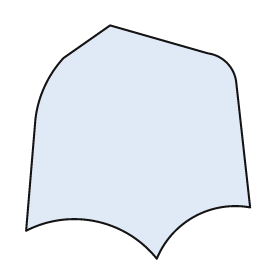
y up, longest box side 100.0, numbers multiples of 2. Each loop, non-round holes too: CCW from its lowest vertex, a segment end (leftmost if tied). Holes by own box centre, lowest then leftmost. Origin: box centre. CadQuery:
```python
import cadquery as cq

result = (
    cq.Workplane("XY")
    .moveTo(8.0, -50.0)
    .threePointArc((24.0, -32.0), (48.0, -28.0))
    .lineTo(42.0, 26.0)
    .threePointArc((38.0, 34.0), (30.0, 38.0))
    .lineTo(-12.0, 50.0)
    .lineTo(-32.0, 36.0)
    .threePointArc((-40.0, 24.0), (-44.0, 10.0))
    .lineTo(-48.0, -38.0)
    .threePointArc((-18.0, -34.0), (8.0, -50.0))
    .close()
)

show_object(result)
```